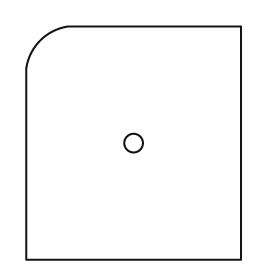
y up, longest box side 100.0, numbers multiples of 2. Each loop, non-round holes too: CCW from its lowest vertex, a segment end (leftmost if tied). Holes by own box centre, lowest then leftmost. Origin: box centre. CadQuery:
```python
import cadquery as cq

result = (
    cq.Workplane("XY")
    .moveTo(-46.0, -50.0)
    .lineTo(46.0, -50.0)
    .lineTo(46.0, 50.0)
    .lineTo(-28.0, 50.0)
    .threePointArc((-40.0, 44.0), (-46.0, 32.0))
    .close()
    .moveTo(0.0, 0.0)
    .circle(4.0)
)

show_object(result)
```